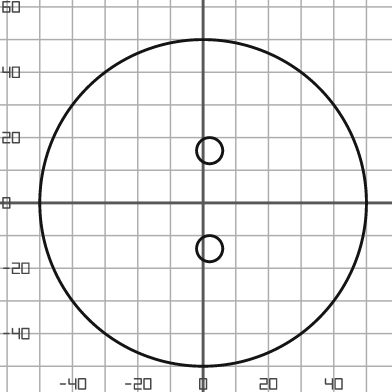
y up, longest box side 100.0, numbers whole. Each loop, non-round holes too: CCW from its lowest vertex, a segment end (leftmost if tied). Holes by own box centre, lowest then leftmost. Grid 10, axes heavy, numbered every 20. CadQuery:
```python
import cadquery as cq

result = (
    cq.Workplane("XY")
    .moveTo(0.0, 0.0)
    .circle(50.0)
    .moveTo(2.0, -14.0)
    .circle(4.0)
    .moveTo(2.0, 16.0)
    .circle(4.0)
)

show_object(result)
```